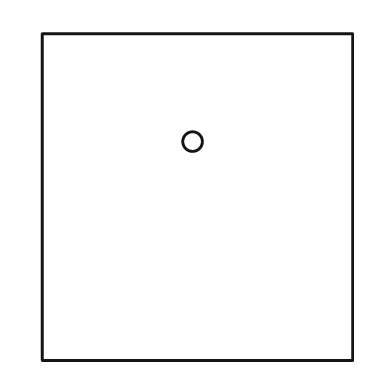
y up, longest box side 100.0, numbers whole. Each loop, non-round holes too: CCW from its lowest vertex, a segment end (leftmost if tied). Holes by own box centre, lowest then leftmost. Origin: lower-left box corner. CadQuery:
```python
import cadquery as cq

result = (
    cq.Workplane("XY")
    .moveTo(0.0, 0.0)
    .lineTo(95.0, 0.0)
    .lineTo(95.0, 100.0)
    .lineTo(0.0, 100.0)
    .close()
    .moveTo(46.0, 67.0)
    .circle(3.0)
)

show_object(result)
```